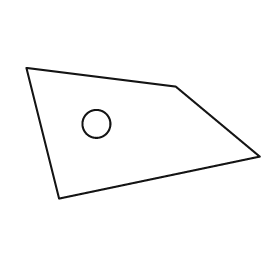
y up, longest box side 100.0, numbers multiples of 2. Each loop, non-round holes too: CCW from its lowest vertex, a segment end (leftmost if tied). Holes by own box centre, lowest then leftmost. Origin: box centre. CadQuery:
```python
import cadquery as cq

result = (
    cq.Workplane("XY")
    .moveTo(-36.0, -28.0)
    .lineTo(50.0, -10.0)
    .lineTo(14.0, 20.0)
    .lineTo(-50.0, 28.0)
    .close()
    .moveTo(-20.0, 4.0)
    .circle(6.0)
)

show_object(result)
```